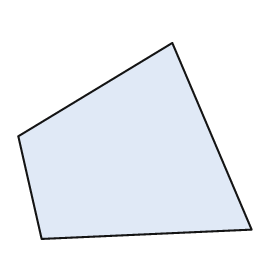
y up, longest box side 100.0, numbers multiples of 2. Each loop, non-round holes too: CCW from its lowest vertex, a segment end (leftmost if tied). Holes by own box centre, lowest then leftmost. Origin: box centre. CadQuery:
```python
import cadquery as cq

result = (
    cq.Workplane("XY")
    .moveTo(-40.0, -42.0)
    .lineTo(50.0, -38.0)
    .lineTo(16.0, 42.0)
    .lineTo(-50.0, 2.0)
    .close()
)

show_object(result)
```